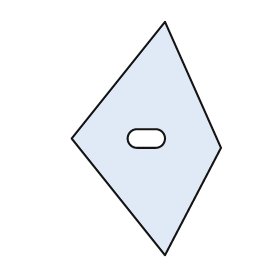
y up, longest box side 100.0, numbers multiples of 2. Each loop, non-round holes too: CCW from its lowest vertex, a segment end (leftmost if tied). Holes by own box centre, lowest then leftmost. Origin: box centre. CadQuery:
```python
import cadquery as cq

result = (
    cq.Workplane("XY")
    .moveTo(8.0, -50.0)
    .lineTo(32.0, -4.0)
    .lineTo(8.0, 50.0)
    .lineTo(-32.0, 0.0)
    .close()
    .moveTo(-4.0, -4.0)
    .lineTo(4.0, -4.0)
    .threePointArc((8.0, 0.0), (4.0, 4.0))
    .lineTo(-4.0, 4.0)
    .threePointArc((-8.0, 0.0), (-4.0, -4.0))
    .close()
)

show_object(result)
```